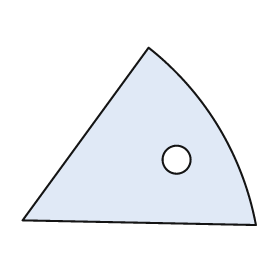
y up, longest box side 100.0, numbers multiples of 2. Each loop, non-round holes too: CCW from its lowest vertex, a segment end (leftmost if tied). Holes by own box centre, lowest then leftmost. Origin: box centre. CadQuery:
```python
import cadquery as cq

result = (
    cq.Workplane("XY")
    .moveTo(50.0, -38.0)
    .threePointArc((34.0, 4.0), (4.0, 38.0))
    .lineTo(-50.0, -36.0)
    .close()
    .moveTo(16.0, -10.0)
    .circle(6.0)
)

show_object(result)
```